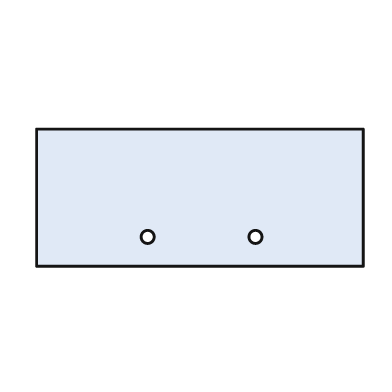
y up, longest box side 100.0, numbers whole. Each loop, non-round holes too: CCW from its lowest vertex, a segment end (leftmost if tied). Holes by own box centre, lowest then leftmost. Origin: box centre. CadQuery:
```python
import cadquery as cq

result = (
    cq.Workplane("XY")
    .moveTo(-50.0, -21.0)
    .lineTo(50.0, -21.0)
    .lineTo(50.0, 21.0)
    .lineTo(-50.0, 21.0)
    .close()
    .moveTo(-16.0, -12.0)
    .circle(2.0)
    .moveTo(17.0, -12.0)
    .circle(2.0)
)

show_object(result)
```